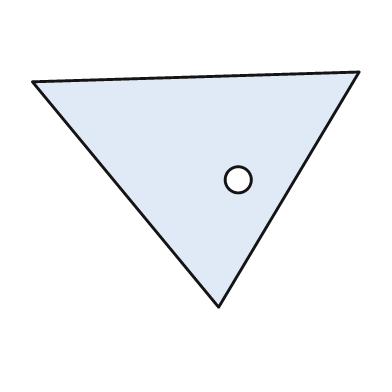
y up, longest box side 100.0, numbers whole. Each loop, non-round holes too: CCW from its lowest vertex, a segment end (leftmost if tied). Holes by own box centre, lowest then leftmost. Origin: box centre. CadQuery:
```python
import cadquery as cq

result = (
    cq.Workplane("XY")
    .moveTo(7.0, -36.0)
    .lineTo(50.0, 36.0)
    .lineTo(-50.0, 33.0)
    .close()
    .moveTo(13.0, 3.0)
    .circle(4.0)
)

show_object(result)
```